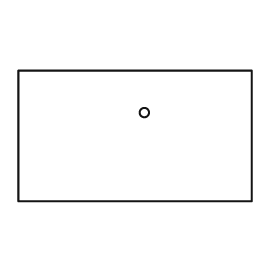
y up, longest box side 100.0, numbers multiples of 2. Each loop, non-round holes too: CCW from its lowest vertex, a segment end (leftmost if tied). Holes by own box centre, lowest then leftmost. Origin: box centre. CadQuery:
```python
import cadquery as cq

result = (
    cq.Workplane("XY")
    .moveTo(-50.0, -28.0)
    .lineTo(50.0, -28.0)
    .lineTo(50.0, 28.0)
    .lineTo(-50.0, 28.0)
    .close()
    .moveTo(4.0, 10.0)
    .circle(2.0)
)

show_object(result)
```